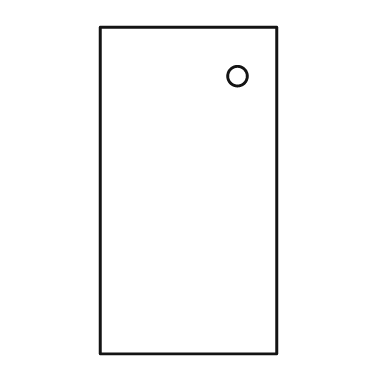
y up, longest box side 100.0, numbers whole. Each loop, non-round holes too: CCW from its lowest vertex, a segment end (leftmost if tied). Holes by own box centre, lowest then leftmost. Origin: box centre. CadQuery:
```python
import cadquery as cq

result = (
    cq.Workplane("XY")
    .moveTo(-27.0, -50.0)
    .lineTo(27.0, -50.0)
    .lineTo(27.0, 50.0)
    .lineTo(-27.0, 50.0)
    .close()
    .moveTo(15.0, 35.0)
    .circle(3.0)
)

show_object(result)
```